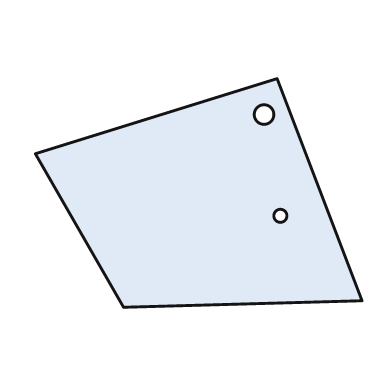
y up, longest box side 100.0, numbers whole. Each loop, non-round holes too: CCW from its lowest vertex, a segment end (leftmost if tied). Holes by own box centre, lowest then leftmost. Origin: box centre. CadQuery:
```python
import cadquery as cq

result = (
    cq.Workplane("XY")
    .moveTo(-23.0, -35.0)
    .lineTo(50.0, -33.0)
    .lineTo(24.0, 35.0)
    .lineTo(-50.0, 12.0)
    .close()
    .moveTo(25.0, -7.0)
    .circle(2.0)
    .moveTo(20.0, 24.0)
    .circle(3.0)
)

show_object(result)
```